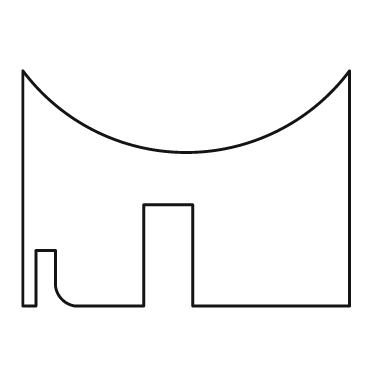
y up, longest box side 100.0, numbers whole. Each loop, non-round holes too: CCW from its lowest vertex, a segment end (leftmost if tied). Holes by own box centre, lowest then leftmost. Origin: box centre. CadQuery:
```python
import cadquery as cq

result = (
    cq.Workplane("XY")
    .moveTo(-50.0, -36.0)
    .lineTo(-46.0, -36.0)
    .lineTo(-46.0, -19.0)
    .lineTo(-40.0, -19.0)
    .lineTo(-40.0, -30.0)
    .threePointArc((-38.0, -34.0), (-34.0, -36.0))
    .lineTo(-13.0, -36.0)
    .lineTo(-13.0, -5.0)
    .lineTo(2.0, -5.0)
    .lineTo(2.0, -36.0)
    .lineTo(50.0, -36.0)
    .lineTo(50.0, 36.0)
    .threePointArc((0.0, 11.0), (-50.0, 36.0))
    .close()
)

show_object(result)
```